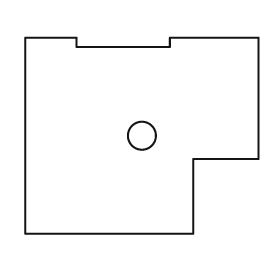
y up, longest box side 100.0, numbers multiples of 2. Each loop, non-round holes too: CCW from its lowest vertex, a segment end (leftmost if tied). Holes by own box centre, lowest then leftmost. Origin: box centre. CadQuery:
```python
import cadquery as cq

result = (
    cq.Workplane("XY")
    .moveTo(-50.0, -42.0)
    .lineTo(22.0, -42.0)
    .lineTo(22.0, -10.0)
    .lineTo(50.0, -10.0)
    .lineTo(50.0, 42.0)
    .lineTo(12.0, 42.0)
    .lineTo(12.0, 38.0)
    .lineTo(-28.0, 38.0)
    .lineTo(-28.0, 42.0)
    .lineTo(-50.0, 42.0)
    .close()
    .moveTo(0.0, 0.0)
    .circle(6.0)
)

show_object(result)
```